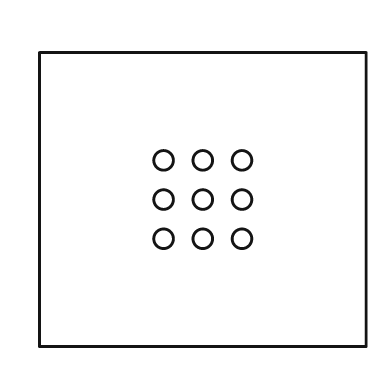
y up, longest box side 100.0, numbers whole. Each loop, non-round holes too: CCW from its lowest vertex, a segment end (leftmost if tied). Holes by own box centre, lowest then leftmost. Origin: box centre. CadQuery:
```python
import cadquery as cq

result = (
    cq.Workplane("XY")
    .moveTo(-50.0, -45.0)
    .lineTo(50.0, -45.0)
    .lineTo(50.0, 45.0)
    .lineTo(-50.0, 45.0)
    .close()
    .moveTo(-12.0, -12.0)
    .circle(3.0)
    .moveTo(0.0, -12.0)
    .circle(3.0)
    .moveTo(12.0, -12.0)
    .circle(3.0)
    .moveTo(-12.0, 0.0)
    .circle(3.0)
    .moveTo(0.0, 0.0)
    .circle(3.0)
    .moveTo(12.0, 0.0)
    .circle(3.0)
    .moveTo(-12.0, 12.0)
    .circle(3.0)
    .moveTo(0.0, 12.0)
    .circle(3.0)
    .moveTo(12.0, 12.0)
    .circle(3.0)
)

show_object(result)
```